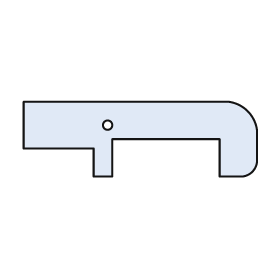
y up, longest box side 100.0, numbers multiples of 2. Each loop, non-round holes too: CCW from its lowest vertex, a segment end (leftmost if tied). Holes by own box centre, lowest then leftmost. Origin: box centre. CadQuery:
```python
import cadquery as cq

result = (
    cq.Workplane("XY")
    .moveTo(-20.0, -16.0)
    .lineTo(-12.0, -16.0)
    .lineTo(-12.0, 0.0)
    .lineTo(34.0, 0.0)
    .lineTo(34.0, -16.0)
    .lineTo(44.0, -16.0)
    .threePointArc((48.0, -14.0), (50.0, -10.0))
    .lineTo(50.0, 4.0)
    .threePointArc((46.0, 12.0), (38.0, 16.0))
    .lineTo(-50.0, 16.0)
    .lineTo(-50.0, -4.0)
    .lineTo(-20.0, -4.0)
    .close()
    .moveTo(-14.0, 6.0)
    .circle(2.0)
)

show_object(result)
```